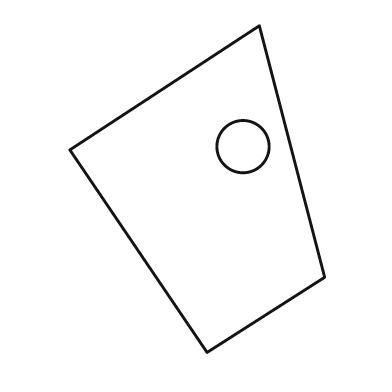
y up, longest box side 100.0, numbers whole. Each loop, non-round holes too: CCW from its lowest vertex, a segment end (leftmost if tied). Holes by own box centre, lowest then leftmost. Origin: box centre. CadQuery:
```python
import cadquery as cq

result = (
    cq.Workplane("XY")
    .moveTo(3.0, -50.0)
    .lineTo(39.0, -27.0)
    .lineTo(19.0, 50.0)
    .lineTo(-39.0, 12.0)
    .close()
    .moveTo(14.0, 13.0)
    .circle(8.0)
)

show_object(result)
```